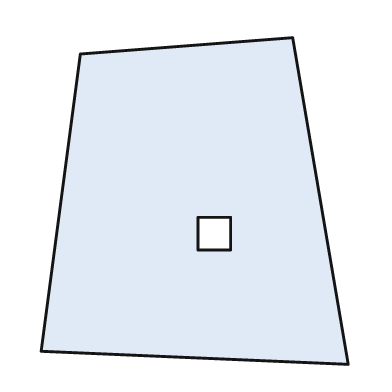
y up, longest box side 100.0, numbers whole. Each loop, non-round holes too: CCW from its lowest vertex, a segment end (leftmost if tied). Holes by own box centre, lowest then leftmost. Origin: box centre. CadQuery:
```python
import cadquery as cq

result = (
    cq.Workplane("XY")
    .moveTo(47.0, -50.0)
    .lineTo(30.0, 50.0)
    .lineTo(-35.0, 45.0)
    .lineTo(-47.0, -46.0)
    .close()
    .moveTo(1.0, -15.0)
    .lineTo(11.0, -15.0)
    .lineTo(11.0, -5.0)
    .lineTo(1.0, -5.0)
    .close()
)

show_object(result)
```